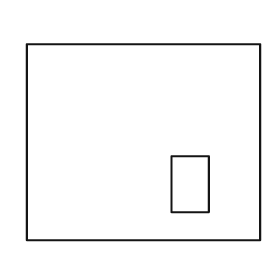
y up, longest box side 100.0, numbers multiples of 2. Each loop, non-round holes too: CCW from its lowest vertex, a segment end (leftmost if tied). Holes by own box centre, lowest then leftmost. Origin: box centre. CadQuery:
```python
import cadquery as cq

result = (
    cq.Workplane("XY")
    .moveTo(-50.0, -42.0)
    .lineTo(50.0, -42.0)
    .lineTo(50.0, 42.0)
    .lineTo(-50.0, 42.0)
    .close()
    .moveTo(12.0, -30.0)
    .lineTo(28.0, -30.0)
    .lineTo(28.0, -6.0)
    .lineTo(12.0, -6.0)
    .close()
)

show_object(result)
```